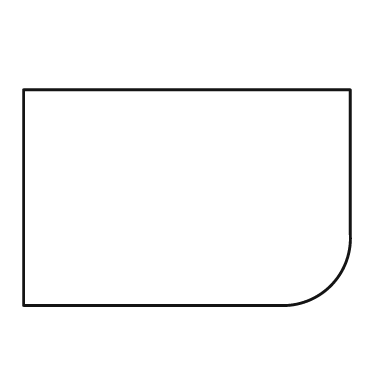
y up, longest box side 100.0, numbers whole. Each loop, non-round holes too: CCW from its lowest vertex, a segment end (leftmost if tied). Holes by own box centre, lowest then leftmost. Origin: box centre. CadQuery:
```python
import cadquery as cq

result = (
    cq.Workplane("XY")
    .moveTo(-50.0, -33.0)
    .lineTo(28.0, -33.0)
    .threePointArc((44.0, -27.0), (50.0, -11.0))
    .lineTo(50.0, 33.0)
    .lineTo(-50.0, 33.0)
    .close()
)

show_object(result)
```